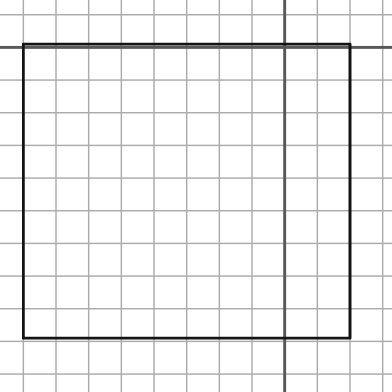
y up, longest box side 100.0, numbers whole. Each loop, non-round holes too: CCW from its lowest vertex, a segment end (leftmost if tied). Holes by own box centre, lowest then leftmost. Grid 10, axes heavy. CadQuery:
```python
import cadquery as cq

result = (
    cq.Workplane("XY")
    .moveTo(-80.0, -89.0)
    .lineTo(20.0, -89.0)
    .lineTo(20.0, 1.0)
    .lineTo(-80.0, 1.0)
    .close()
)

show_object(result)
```